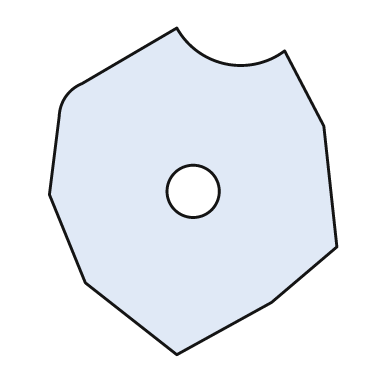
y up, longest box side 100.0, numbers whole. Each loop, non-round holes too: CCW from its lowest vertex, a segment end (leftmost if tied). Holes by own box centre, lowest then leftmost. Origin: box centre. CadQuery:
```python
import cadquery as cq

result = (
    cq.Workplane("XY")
    .moveTo(-5.0, -50.0)
    .lineTo(24.0, -34.0)
    .lineTo(44.0, -17.0)
    .lineTo(40.0, 20.0)
    .lineTo(28.0, 43.0)
    .threePointArc((10.0, 39.0), (-5.0, 50.0))
    .lineTo(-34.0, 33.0)
    .threePointArc((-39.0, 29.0), (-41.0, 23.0))
    .lineTo(-44.0, -1.0)
    .lineTo(-33.0, -28.0)
    .close()
    .moveTo(0.0, 0.0)
    .circle(8.0)
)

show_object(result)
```